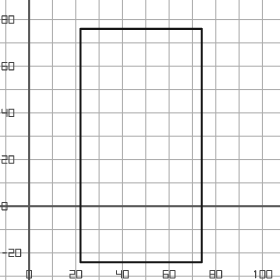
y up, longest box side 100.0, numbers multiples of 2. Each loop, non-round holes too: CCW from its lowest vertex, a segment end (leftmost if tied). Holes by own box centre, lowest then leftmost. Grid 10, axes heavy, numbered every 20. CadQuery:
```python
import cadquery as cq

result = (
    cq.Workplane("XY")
    .moveTo(22.0, -24.0)
    .lineTo(74.0, -24.0)
    .lineTo(74.0, 76.0)
    .lineTo(22.0, 76.0)
    .close()
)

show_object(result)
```